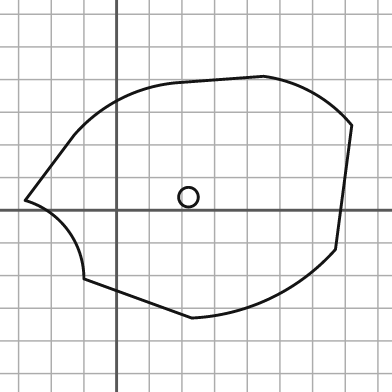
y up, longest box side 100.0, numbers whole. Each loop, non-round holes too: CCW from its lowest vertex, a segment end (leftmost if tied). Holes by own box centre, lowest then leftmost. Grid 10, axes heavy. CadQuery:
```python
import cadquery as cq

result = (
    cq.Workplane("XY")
    .moveTo(23.0, -33.0)
    .threePointArc((47.0, -27.0), (67.0, -12.0))
    .lineTo(72.0, 26.0)
    .threePointArc((60.0, 36.0), (45.0, 41.0))
    .lineTo(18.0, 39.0)
    .threePointArc((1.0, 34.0), (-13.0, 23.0))
    .lineTo(-28.0, 3.0)
    .threePointArc((-15.0, -6.0), (-10.0, -21.0))
    .close()
    .moveTo(22.0, 4.0)
    .circle(3.0)
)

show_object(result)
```